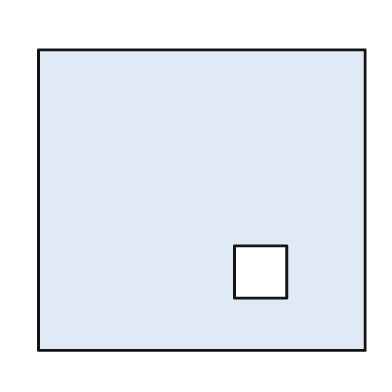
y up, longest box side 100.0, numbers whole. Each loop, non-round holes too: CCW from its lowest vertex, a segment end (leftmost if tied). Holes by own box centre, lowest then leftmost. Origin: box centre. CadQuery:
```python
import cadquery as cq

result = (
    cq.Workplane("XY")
    .moveTo(-50.0, -46.0)
    .lineTo(50.0, -46.0)
    .lineTo(50.0, 46.0)
    .lineTo(-50.0, 46.0)
    .close()
    .moveTo(10.0, -30.0)
    .lineTo(26.0, -30.0)
    .lineTo(26.0, -14.0)
    .lineTo(10.0, -14.0)
    .close()
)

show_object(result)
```